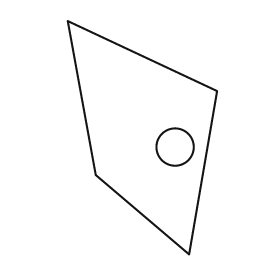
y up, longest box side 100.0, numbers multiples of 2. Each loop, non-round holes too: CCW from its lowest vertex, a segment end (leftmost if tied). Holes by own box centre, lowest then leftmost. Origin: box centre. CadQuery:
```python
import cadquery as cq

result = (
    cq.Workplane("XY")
    .moveTo(20.0, -50.0)
    .lineTo(32.0, 20.0)
    .lineTo(-32.0, 50.0)
    .lineTo(-20.0, -16.0)
    .close()
    .moveTo(14.0, -4.0)
    .circle(8.0)
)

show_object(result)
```